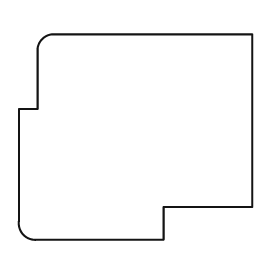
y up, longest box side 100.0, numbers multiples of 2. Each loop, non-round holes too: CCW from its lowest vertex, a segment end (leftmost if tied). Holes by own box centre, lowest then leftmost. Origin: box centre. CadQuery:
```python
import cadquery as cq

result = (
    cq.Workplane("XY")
    .moveTo(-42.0, -44.0)
    .lineTo(12.0, -44.0)
    .lineTo(12.0, -30.0)
    .lineTo(50.0, -30.0)
    .lineTo(50.0, 44.0)
    .lineTo(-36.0, 44.0)
    .threePointArc((-40.0, 42.0), (-42.0, 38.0))
    .lineTo(-42.0, 12.0)
    .lineTo(-50.0, 12.0)
    .lineTo(-50.0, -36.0)
    .threePointArc((-48.0, -42.0), (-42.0, -44.0))
    .close()
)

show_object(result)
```